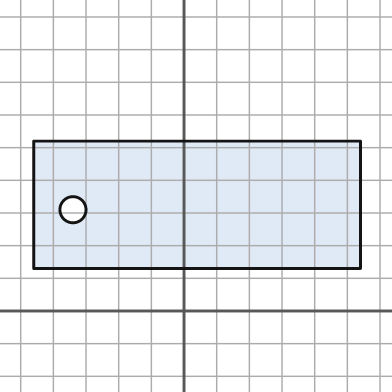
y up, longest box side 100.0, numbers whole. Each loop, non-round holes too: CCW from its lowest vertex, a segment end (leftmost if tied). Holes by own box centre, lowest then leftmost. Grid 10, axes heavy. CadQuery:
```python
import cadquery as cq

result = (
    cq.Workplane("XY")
    .moveTo(-46.0, 13.0)
    .lineTo(54.0, 13.0)
    .lineTo(54.0, 52.0)
    .lineTo(-46.0, 52.0)
    .close()
    .moveTo(-34.0, 31.0)
    .circle(4.0)
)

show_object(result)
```